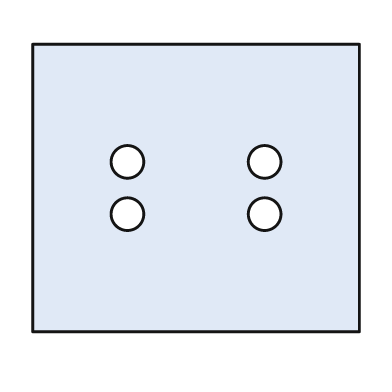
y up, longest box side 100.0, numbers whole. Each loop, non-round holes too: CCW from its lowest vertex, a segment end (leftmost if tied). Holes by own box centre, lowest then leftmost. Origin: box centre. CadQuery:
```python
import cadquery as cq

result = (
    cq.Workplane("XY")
    .moveTo(-50.0, -44.0)
    .lineTo(50.0, -44.0)
    .lineTo(50.0, 44.0)
    .lineTo(-50.0, 44.0)
    .close()
    .moveTo(-21.0, -8.0)
    .circle(5.0)
    .moveTo(21.0, -8.0)
    .circle(5.0)
    .moveTo(-21.0, 8.0)
    .circle(5.0)
    .moveTo(21.0, 8.0)
    .circle(5.0)
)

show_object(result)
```